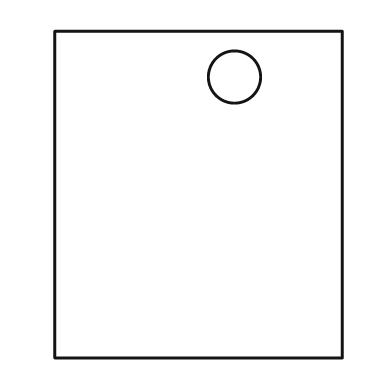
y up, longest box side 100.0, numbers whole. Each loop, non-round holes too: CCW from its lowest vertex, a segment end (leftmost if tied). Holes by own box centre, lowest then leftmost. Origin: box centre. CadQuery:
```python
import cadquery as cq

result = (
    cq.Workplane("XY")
    .moveTo(-44.0, -50.0)
    .lineTo(44.0, -50.0)
    .lineTo(44.0, 50.0)
    .lineTo(-44.0, 50.0)
    .close()
    .moveTo(11.0, 36.0)
    .circle(8.0)
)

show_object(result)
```